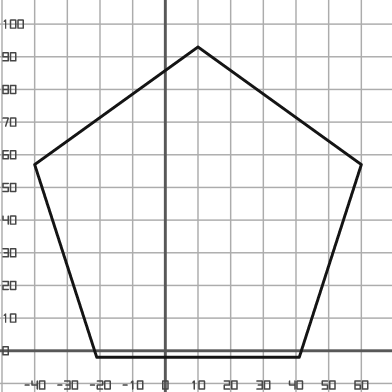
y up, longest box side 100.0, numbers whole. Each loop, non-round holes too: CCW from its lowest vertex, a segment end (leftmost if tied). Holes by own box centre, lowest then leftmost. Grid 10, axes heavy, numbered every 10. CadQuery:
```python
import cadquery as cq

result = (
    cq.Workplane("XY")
    .moveTo(-21.0, -2.0)
    .lineTo(41.0, -2.0)
    .lineTo(60.0, 57.0)
    .lineTo(10.0, 93.0)
    .lineTo(-40.0, 57.0)
    .close()
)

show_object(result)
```